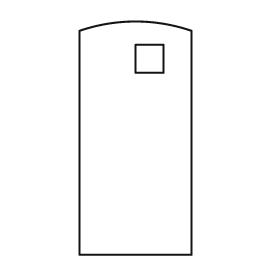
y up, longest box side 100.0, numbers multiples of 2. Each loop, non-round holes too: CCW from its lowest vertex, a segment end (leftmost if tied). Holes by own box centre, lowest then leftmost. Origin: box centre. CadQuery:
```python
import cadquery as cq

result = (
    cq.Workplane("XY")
    .moveTo(-24.0, -50.0)
    .lineTo(24.0, -50.0)
    .lineTo(24.0, 46.0)
    .threePointArc((0.0, 50.0), (-24.0, 46.0))
    .close()
    .moveTo(0.0, 28.0)
    .lineTo(12.0, 28.0)
    .lineTo(12.0, 40.0)
    .lineTo(0.0, 40.0)
    .close()
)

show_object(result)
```